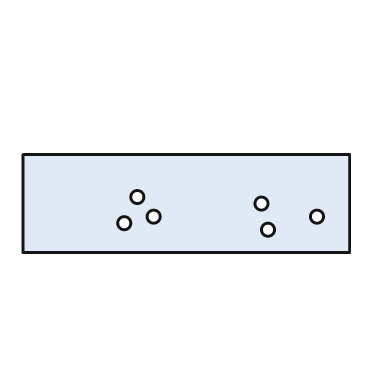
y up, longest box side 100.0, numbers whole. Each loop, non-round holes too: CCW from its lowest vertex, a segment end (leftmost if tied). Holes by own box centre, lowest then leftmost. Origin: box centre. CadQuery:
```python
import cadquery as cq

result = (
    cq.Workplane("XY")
    .moveTo(-50.0, -15.0)
    .lineTo(50.0, -15.0)
    .lineTo(50.0, 15.0)
    .lineTo(-50.0, 15.0)
    .close()
    .moveTo(25.0, -8.0)
    .circle(2.0)
    .moveTo(-19.0, -6.0)
    .circle(2.0)
    .moveTo(-10.0, -4.0)
    .circle(2.0)
    .moveTo(40.0, -4.0)
    .circle(2.0)
    .moveTo(23.0, 0.0)
    .circle(2.0)
    .moveTo(-15.0, 2.0)
    .circle(2.0)
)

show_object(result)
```